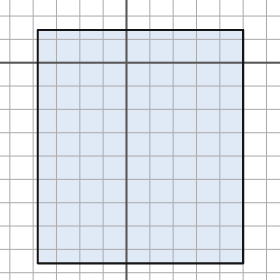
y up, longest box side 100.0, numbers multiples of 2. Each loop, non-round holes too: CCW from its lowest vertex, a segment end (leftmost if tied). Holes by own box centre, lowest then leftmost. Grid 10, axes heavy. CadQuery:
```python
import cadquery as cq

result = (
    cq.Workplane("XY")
    .moveTo(-38.0, -86.0)
    .lineTo(50.0, -86.0)
    .lineTo(50.0, 14.0)
    .lineTo(-38.0, 14.0)
    .close()
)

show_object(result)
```